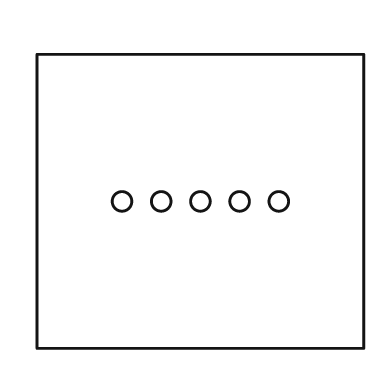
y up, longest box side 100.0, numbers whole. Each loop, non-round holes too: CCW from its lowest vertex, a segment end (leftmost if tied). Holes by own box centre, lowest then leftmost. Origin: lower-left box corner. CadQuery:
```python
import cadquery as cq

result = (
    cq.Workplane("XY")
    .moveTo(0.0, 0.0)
    .lineTo(100.0, 0.0)
    .lineTo(100.0, 90.0)
    .lineTo(0.0, 90.0)
    .close()
    .moveTo(26.0, 45.0)
    .circle(3.0)
    .moveTo(38.0, 45.0)
    .circle(3.0)
    .moveTo(50.0, 45.0)
    .circle(3.0)
    .moveTo(62.0, 45.0)
    .circle(3.0)
    .moveTo(74.0, 45.0)
    .circle(3.0)
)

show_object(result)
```